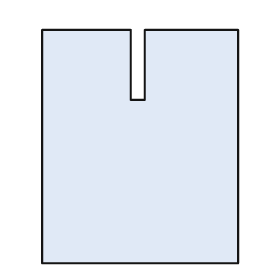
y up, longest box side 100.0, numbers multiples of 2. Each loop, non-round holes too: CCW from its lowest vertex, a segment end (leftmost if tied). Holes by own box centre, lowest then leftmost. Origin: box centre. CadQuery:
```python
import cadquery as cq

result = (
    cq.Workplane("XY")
    .moveTo(-42.0, -50.0)
    .lineTo(42.0, -50.0)
    .lineTo(42.0, 50.0)
    .lineTo(2.0, 50.0)
    .lineTo(2.0, 20.0)
    .lineTo(-4.0, 20.0)
    .lineTo(-4.0, 50.0)
    .lineTo(-42.0, 50.0)
    .close()
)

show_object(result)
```